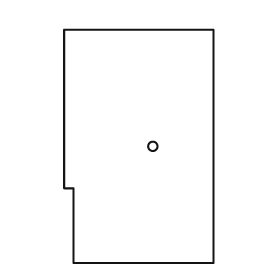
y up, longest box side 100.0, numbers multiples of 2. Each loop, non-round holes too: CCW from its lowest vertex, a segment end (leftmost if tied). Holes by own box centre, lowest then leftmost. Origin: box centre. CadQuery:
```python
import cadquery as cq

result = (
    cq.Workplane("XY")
    .moveTo(-28.0, -50.0)
    .lineTo(32.0, -50.0)
    .lineTo(32.0, 50.0)
    .lineTo(-32.0, 50.0)
    .lineTo(-32.0, -18.0)
    .lineTo(-28.0, -18.0)
    .close()
    .moveTo(6.0, 0.0)
    .circle(2.0)
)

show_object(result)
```